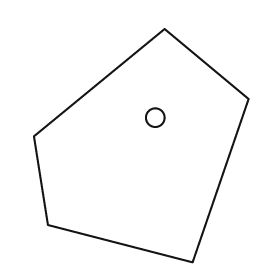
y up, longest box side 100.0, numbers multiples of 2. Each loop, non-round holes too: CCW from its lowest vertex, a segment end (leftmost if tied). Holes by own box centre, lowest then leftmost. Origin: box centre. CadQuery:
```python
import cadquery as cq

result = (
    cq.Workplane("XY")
    .moveTo(22.0, -50.0)
    .lineTo(46.0, 20.0)
    .lineTo(10.0, 50.0)
    .lineTo(-46.0, 4.0)
    .lineTo(-40.0, -34.0)
    .close()
    .moveTo(6.0, 12.0)
    .circle(4.0)
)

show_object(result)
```